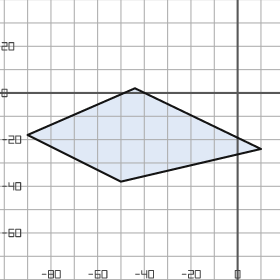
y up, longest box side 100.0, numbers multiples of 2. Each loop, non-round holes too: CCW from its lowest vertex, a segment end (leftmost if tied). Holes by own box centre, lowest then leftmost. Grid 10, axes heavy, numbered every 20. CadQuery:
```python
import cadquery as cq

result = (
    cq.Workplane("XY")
    .moveTo(-50.0, -38.0)
    .lineTo(10.0, -24.0)
    .lineTo(-44.0, 2.0)
    .lineTo(-90.0, -18.0)
    .close()
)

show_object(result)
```